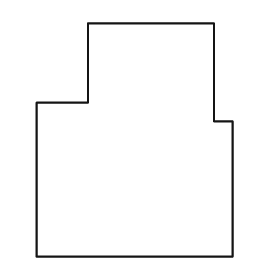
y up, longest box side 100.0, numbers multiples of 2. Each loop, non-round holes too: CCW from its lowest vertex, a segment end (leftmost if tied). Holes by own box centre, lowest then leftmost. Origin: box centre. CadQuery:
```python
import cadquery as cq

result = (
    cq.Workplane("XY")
    .moveTo(-42.0, -50.0)
    .lineTo(42.0, -50.0)
    .lineTo(42.0, 8.0)
    .lineTo(34.0, 8.0)
    .lineTo(34.0, 50.0)
    .lineTo(-20.0, 50.0)
    .lineTo(-20.0, 16.0)
    .lineTo(-42.0, 16.0)
    .close()
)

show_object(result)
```